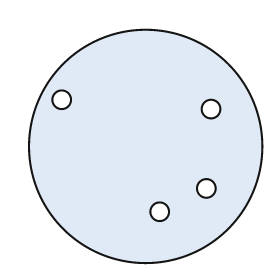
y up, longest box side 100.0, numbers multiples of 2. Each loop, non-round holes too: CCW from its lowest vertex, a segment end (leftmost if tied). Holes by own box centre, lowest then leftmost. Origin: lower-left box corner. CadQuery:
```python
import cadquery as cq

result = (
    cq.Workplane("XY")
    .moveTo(50.0, 50.0)
    .circle(50.0)
    .moveTo(56.0, 22.0)
    .circle(4.0)
    .moveTo(76.0, 32.0)
    .circle(4.0)
    .moveTo(78.0, 66.0)
    .circle(4.0)
    .moveTo(14.0, 70.0)
    .circle(4.0)
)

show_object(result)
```